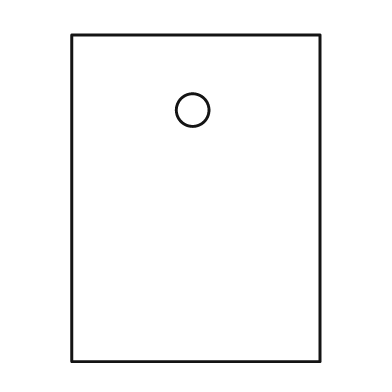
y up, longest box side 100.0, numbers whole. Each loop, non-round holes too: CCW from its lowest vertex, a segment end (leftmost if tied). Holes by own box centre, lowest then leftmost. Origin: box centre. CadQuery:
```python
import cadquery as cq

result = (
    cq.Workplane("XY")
    .moveTo(-38.0, -50.0)
    .lineTo(38.0, -50.0)
    .lineTo(38.0, 50.0)
    .lineTo(-38.0, 50.0)
    .close()
    .moveTo(-1.0, 27.0)
    .circle(5.0)
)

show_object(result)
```